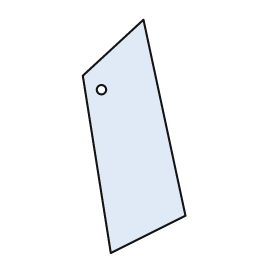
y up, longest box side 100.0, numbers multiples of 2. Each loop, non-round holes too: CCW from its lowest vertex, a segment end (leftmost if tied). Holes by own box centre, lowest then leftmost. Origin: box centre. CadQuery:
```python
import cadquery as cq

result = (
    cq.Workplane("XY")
    .moveTo(-10.0, -50.0)
    .lineTo(22.0, -34.0)
    .lineTo(4.0, 50.0)
    .lineTo(-22.0, 26.0)
    .close()
    .moveTo(-14.0, 20.0)
    .circle(2.0)
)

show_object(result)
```